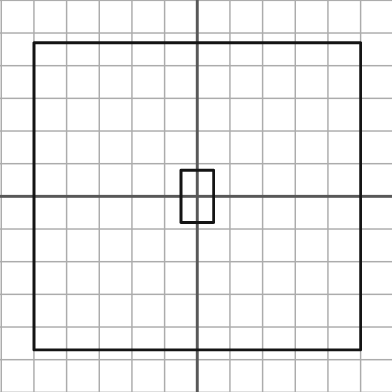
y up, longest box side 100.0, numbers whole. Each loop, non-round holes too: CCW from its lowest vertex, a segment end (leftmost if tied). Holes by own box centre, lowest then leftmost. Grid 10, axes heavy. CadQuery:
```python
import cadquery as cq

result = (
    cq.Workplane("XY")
    .moveTo(-50.0, -47.0)
    .lineTo(50.0, -47.0)
    .lineTo(50.0, 47.0)
    .lineTo(-50.0, 47.0)
    .close()
    .moveTo(-5.0, -8.0)
    .lineTo(5.0, -8.0)
    .lineTo(5.0, 8.0)
    .lineTo(-5.0, 8.0)
    .close()
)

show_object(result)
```